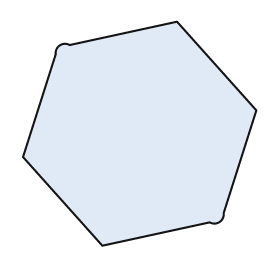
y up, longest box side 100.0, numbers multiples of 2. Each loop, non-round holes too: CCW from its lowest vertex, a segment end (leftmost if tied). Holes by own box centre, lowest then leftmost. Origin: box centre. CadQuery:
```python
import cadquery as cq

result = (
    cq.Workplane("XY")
    .moveTo(-16.0, -48.0)
    .lineTo(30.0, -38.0)
    .threePointArc((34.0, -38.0), (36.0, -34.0))
    .lineTo(50.0, 10.0)
    .lineTo(16.0, 48.0)
    .lineTo(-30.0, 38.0)
    .threePointArc((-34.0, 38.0), (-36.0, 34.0))
    .lineTo(-50.0, -10.0)
    .close()
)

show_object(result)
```